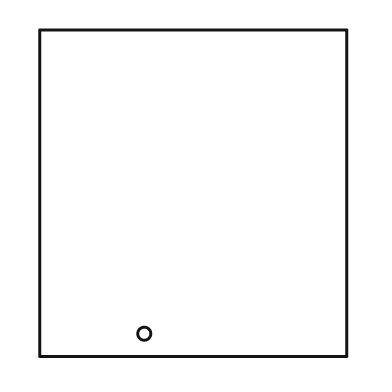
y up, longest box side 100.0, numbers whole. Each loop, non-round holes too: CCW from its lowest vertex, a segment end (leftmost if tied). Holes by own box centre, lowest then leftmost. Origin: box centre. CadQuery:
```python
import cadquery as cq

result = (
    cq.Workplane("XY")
    .moveTo(-47.0, -50.0)
    .lineTo(47.0, -50.0)
    .lineTo(47.0, 50.0)
    .lineTo(-47.0, 50.0)
    .close()
    .moveTo(-15.0, -43.0)
    .circle(2.0)
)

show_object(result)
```